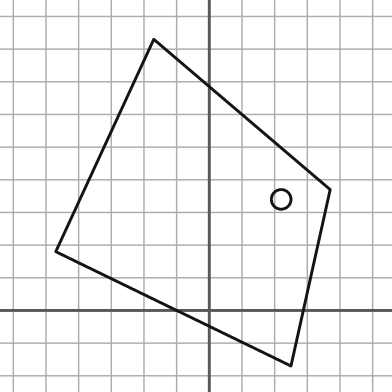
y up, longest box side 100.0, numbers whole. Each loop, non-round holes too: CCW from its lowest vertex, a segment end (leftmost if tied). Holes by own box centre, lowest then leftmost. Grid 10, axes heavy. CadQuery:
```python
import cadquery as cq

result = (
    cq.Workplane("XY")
    .moveTo(25.0, -17.0)
    .lineTo(37.0, 37.0)
    .lineTo(-17.0, 83.0)
    .lineTo(-47.0, 18.0)
    .close()
    .moveTo(22.0, 34.0)
    .circle(3.0)
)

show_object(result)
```